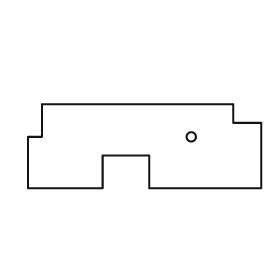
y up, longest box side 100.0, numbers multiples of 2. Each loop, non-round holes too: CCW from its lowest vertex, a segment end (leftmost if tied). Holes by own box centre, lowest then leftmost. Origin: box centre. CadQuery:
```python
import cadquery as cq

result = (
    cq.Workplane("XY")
    .moveTo(-50.0, -18.0)
    .lineTo(-18.0, -18.0)
    .lineTo(-18.0, -4.0)
    .lineTo(2.0, -4.0)
    .lineTo(2.0, -18.0)
    .lineTo(50.0, -18.0)
    .lineTo(50.0, 10.0)
    .lineTo(38.0, 10.0)
    .lineTo(38.0, 18.0)
    .lineTo(-44.0, 18.0)
    .lineTo(-44.0, 4.0)
    .lineTo(-50.0, 4.0)
    .close()
    .moveTo(20.0, 4.0)
    .circle(2.0)
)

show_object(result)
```